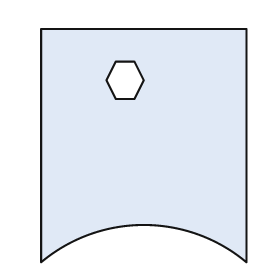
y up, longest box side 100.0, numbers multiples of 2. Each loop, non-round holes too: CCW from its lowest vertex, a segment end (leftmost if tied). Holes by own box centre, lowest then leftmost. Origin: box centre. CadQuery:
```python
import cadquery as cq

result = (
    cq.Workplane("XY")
    .moveTo(-44.0, -50.0)
    .threePointArc((0.0, -34.0), (44.0, -50.0))
    .lineTo(44.0, 50.0)
    .lineTo(-44.0, 50.0)
    .close()
    .moveTo(-12.0, 20.0)
    .lineTo(-4.0, 20.0)
    .lineTo(0.0, 28.0)
    .lineTo(-4.0, 36.0)
    .lineTo(-12.0, 36.0)
    .lineTo(-16.0, 28.0)
    .close()
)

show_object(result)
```